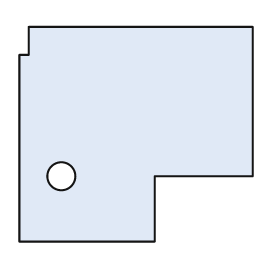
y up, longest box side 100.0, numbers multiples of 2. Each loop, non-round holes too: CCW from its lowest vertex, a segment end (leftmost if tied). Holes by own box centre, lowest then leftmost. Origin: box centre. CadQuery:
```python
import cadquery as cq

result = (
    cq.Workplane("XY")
    .moveTo(-50.0, -46.0)
    .lineTo(8.0, -46.0)
    .lineTo(8.0, -18.0)
    .lineTo(50.0, -18.0)
    .lineTo(50.0, 46.0)
    .lineTo(-46.0, 46.0)
    .lineTo(-46.0, 34.0)
    .lineTo(-50.0, 34.0)
    .close()
    .moveTo(-32.0, -18.0)
    .circle(6.0)
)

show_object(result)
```